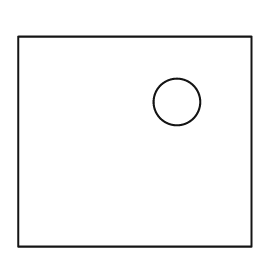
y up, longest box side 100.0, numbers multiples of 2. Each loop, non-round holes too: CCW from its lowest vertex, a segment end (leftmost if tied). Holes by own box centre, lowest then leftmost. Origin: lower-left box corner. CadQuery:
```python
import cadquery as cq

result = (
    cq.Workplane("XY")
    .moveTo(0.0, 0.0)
    .lineTo(100.0, 0.0)
    .lineTo(100.0, 90.0)
    .lineTo(0.0, 90.0)
    .close()
    .moveTo(68.0, 62.0)
    .circle(10.0)
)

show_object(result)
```